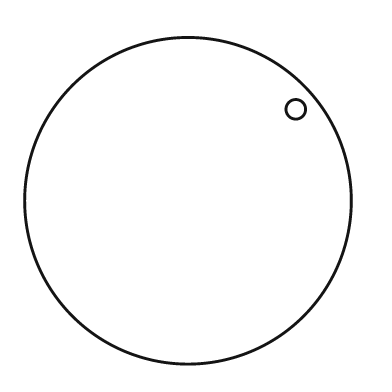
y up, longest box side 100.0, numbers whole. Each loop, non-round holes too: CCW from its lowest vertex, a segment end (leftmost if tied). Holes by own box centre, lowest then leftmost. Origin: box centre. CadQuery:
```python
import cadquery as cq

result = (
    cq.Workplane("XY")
    .moveTo(0.0, 0.0)
    .circle(50.0)
    .moveTo(33.0, 28.0)
    .circle(3.0)
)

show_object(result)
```